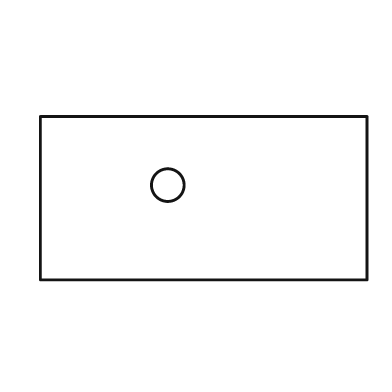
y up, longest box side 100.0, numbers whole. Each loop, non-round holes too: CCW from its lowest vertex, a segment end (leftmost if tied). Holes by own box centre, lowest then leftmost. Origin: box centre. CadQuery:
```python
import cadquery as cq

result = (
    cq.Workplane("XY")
    .moveTo(-50.0, -25.0)
    .lineTo(50.0, -25.0)
    .lineTo(50.0, 25.0)
    .lineTo(-50.0, 25.0)
    .close()
    .moveTo(-11.0, 4.0)
    .circle(5.0)
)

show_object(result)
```